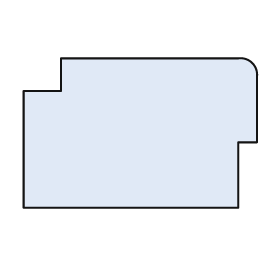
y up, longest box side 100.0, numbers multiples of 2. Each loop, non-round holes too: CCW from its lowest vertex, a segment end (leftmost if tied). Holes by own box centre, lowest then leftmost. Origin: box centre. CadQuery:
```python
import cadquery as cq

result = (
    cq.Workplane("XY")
    .moveTo(-50.0, -32.0)
    .lineTo(42.0, -32.0)
    .lineTo(42.0, -4.0)
    .lineTo(50.0, -4.0)
    .lineTo(50.0, 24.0)
    .threePointArc((48.0, 30.0), (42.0, 32.0))
    .lineTo(-34.0, 32.0)
    .lineTo(-34.0, 18.0)
    .lineTo(-50.0, 18.0)
    .close()
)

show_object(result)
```